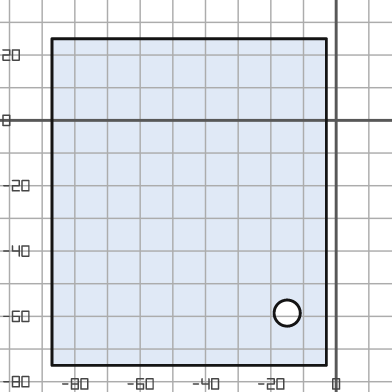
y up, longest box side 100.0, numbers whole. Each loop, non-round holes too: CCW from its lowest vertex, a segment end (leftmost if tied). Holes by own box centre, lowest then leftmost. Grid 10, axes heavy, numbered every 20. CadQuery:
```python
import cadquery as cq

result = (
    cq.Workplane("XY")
    .moveTo(-87.0, -75.0)
    .lineTo(-3.0, -75.0)
    .lineTo(-3.0, 25.0)
    .lineTo(-87.0, 25.0)
    .close()
    .moveTo(-15.0, -59.0)
    .circle(4.0)
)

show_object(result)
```